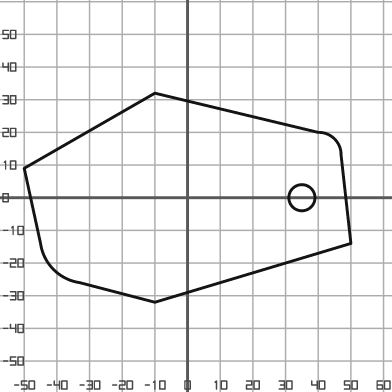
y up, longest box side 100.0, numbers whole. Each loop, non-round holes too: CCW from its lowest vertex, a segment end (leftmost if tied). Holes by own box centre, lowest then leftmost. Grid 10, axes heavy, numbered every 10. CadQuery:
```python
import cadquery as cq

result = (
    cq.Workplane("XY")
    .moveTo(-10.0, -32.0)
    .lineTo(50.0, -14.0)
    .lineTo(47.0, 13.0)
    .threePointArc((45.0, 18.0), (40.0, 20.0))
    .lineTo(-10.0, 32.0)
    .lineTo(-50.0, 9.0)
    .lineTo(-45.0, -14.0)
    .threePointArc((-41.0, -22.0), (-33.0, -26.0))
    .close()
    .moveTo(35.0, 0.0)
    .circle(4.0)
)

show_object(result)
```